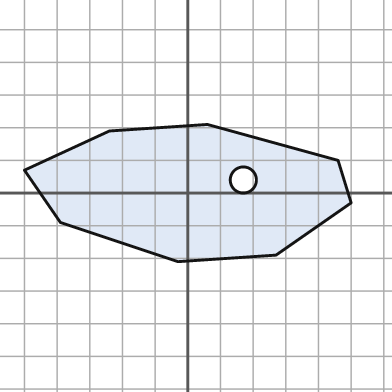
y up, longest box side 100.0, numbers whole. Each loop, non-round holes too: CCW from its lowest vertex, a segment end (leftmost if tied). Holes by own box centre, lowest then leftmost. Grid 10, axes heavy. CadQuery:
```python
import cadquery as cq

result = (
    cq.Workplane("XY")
    .moveTo(-3.0, -21.0)
    .lineTo(27.0, -19.0)
    .lineTo(50.0, -3.0)
    .lineTo(46.0, 10.0)
    .lineTo(6.0, 21.0)
    .lineTo(-24.0, 19.0)
    .lineTo(-50.0, 7.0)
    .lineTo(-39.0, -9.0)
    .close()
    .moveTo(17.0, 4.0)
    .circle(4.0)
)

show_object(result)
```